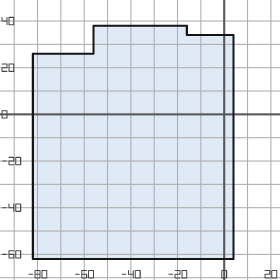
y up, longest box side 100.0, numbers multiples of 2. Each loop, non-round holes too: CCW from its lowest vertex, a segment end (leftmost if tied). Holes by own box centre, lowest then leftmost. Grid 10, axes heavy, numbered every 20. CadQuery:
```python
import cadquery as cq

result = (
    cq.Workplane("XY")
    .moveTo(-82.0, -62.0)
    .lineTo(4.0, -62.0)
    .lineTo(4.0, 34.0)
    .lineTo(-16.0, 34.0)
    .lineTo(-16.0, 38.0)
    .lineTo(-56.0, 38.0)
    .lineTo(-56.0, 26.0)
    .lineTo(-82.0, 26.0)
    .close()
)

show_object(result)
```